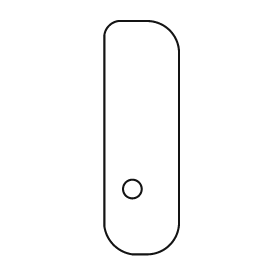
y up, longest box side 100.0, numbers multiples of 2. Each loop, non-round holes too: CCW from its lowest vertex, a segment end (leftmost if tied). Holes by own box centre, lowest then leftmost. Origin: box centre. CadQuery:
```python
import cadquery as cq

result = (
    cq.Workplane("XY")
    .moveTo(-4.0, -50.0)
    .lineTo(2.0, -50.0)
    .threePointArc((12.0, -46.0), (16.0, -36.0))
    .lineTo(16.0, 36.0)
    .threePointArc((12.0, 46.0), (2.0, 50.0))
    .lineTo(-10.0, 50.0)
    .threePointArc((-14.0, 48.0), (-16.0, 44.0))
    .lineTo(-16.0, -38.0)
    .threePointArc((-12.0, -46.0), (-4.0, -50.0))
    .close()
    .moveTo(-4.0, -22.0)
    .circle(4.0)
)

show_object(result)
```